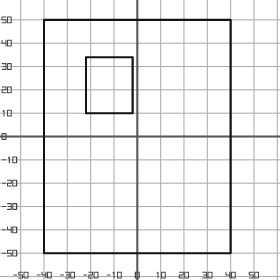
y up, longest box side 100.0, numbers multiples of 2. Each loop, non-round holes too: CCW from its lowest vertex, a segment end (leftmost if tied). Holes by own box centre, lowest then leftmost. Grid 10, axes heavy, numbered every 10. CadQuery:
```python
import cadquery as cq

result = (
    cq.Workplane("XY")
    .moveTo(-40.0, -50.0)
    .lineTo(40.0, -50.0)
    .lineTo(40.0, 50.0)
    .lineTo(-40.0, 50.0)
    .close()
    .moveTo(-22.0, 10.0)
    .lineTo(-2.0, 10.0)
    .lineTo(-2.0, 34.0)
    .lineTo(-22.0, 34.0)
    .close()
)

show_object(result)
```